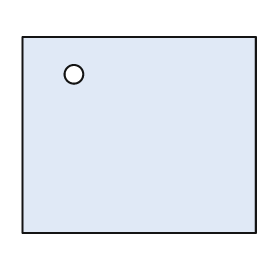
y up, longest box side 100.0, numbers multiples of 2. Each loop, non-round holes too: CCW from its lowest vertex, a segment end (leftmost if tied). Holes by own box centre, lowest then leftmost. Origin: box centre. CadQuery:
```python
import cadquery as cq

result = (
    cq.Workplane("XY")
    .moveTo(-50.0, -42.0)
    .lineTo(50.0, -42.0)
    .lineTo(50.0, 42.0)
    .lineTo(-50.0, 42.0)
    .close()
    .moveTo(-28.0, 26.0)
    .circle(4.0)
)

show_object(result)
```